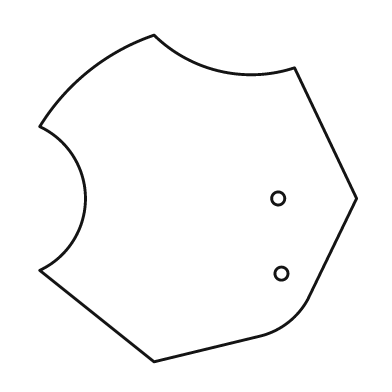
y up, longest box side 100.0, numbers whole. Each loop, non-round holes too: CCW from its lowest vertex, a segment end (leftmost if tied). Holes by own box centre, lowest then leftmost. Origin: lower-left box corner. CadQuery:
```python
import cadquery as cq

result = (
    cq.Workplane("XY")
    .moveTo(35.0, 0.0)
    .lineTo(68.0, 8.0)
    .threePointArc((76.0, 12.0), (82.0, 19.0))
    .lineTo(97.0, 50.0)
    .lineTo(78.0, 90.0)
    .threePointArc((55.0, 89.0), (35.0, 100.0))
    .threePointArc((15.0, 89.0), (0.0, 72.0))
    .threePointArc((14.0, 50.0), (0.0, 28.0))
    .close()
    .moveTo(74.0, 27.0)
    .circle(2.0)
    .moveTo(73.0, 50.0)
    .circle(2.0)
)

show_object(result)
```